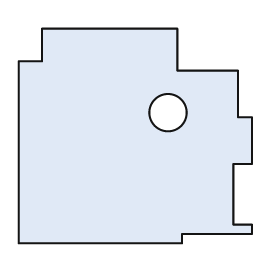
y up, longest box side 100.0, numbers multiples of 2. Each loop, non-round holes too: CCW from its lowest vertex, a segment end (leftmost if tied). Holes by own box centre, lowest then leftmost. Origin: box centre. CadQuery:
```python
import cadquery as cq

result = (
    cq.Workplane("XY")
    .moveTo(-50.0, -46.0)
    .lineTo(20.0, -46.0)
    .lineTo(20.0, -42.0)
    .lineTo(50.0, -42.0)
    .lineTo(50.0, -38.0)
    .lineTo(42.0, -38.0)
    .lineTo(42.0, -12.0)
    .lineTo(50.0, -12.0)
    .lineTo(50.0, 8.0)
    .lineTo(44.0, 8.0)
    .lineTo(44.0, 28.0)
    .lineTo(18.0, 28.0)
    .lineTo(18.0, 46.0)
    .lineTo(-40.0, 46.0)
    .lineTo(-40.0, 32.0)
    .lineTo(-50.0, 32.0)
    .close()
    .moveTo(14.0, 10.0)
    .circle(8.0)
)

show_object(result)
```